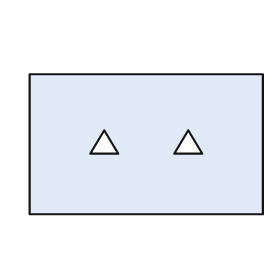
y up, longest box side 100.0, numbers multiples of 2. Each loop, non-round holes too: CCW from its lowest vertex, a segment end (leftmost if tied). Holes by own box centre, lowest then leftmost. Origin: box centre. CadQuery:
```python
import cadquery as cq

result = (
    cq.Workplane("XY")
    .moveTo(-50.0, -30.0)
    .lineTo(50.0, -30.0)
    .lineTo(50.0, 30.0)
    .lineTo(-50.0, 30.0)
    .close()
    .moveTo(-24.0, -4.0)
    .lineTo(-12.0, -4.0)
    .lineTo(-18.0, 6.0)
    .close()
    .moveTo(12.0, -4.0)
    .lineTo(24.0, -4.0)
    .lineTo(18.0, 6.0)
    .close()
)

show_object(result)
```